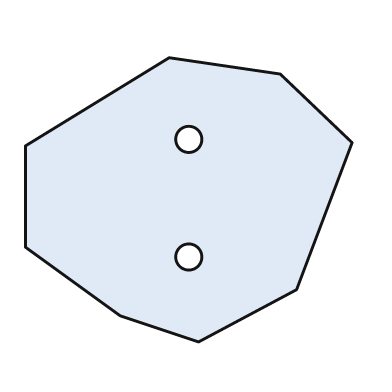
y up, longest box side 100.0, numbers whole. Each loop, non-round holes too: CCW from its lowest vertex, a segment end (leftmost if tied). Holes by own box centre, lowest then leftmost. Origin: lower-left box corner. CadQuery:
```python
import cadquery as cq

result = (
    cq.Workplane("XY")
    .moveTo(53.0, 0.0)
    .lineTo(83.0, 16.0)
    .lineTo(100.0, 61.0)
    .lineTo(78.0, 82.0)
    .lineTo(44.0, 87.0)
    .lineTo(0.0, 60.0)
    .lineTo(0.0, 29.0)
    .lineTo(29.0, 8.0)
    .close()
    .moveTo(50.0, 26.0)
    .circle(4.0)
    .moveTo(50.0, 62.0)
    .circle(4.0)
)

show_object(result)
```